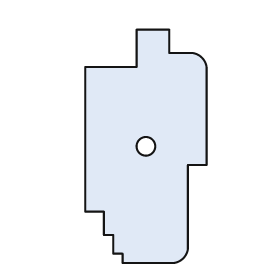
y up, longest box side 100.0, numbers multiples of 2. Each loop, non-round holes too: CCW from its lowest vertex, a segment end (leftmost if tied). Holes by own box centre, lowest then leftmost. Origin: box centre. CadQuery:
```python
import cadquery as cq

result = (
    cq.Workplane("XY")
    .moveTo(-10.0, -50.0)
    .lineTo(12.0, -50.0)
    .threePointArc((16.0, -48.0), (18.0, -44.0))
    .lineTo(18.0, -8.0)
    .lineTo(26.0, -8.0)
    .lineTo(26.0, 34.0)
    .threePointArc((24.0, 38.0), (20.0, 40.0))
    .lineTo(10.0, 40.0)
    .lineTo(10.0, 50.0)
    .lineTo(-4.0, 50.0)
    .lineTo(-4.0, 34.0)
    .lineTo(-26.0, 34.0)
    .lineTo(-26.0, -28.0)
    .lineTo(-18.0, -28.0)
    .lineTo(-18.0, -38.0)
    .lineTo(-14.0, -38.0)
    .lineTo(-14.0, -46.0)
    .lineTo(-10.0, -46.0)
    .close()
    .moveTo(0.0, 0.0)
    .circle(4.0)
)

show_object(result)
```